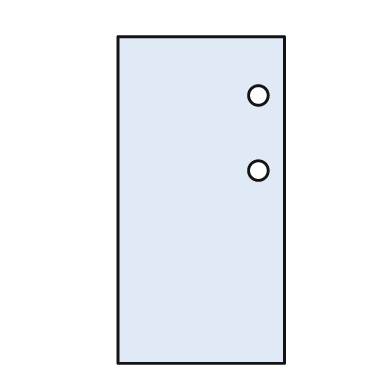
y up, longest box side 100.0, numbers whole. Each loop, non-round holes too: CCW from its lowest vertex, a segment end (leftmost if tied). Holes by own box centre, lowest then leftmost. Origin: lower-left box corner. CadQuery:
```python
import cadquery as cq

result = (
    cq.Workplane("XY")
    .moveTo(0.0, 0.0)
    .lineTo(51.0, 0.0)
    .lineTo(51.0, 100.0)
    .lineTo(0.0, 100.0)
    .close()
    .moveTo(43.0, 59.0)
    .circle(3.0)
    .moveTo(43.0, 82.0)
    .circle(3.0)
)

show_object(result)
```